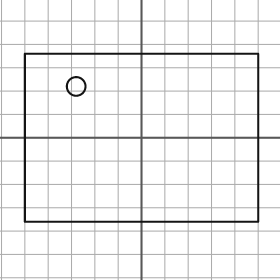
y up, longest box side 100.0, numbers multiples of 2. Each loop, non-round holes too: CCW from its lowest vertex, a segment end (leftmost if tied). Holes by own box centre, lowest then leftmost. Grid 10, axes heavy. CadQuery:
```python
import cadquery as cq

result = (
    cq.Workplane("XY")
    .moveTo(-50.0, -36.0)
    .lineTo(50.0, -36.0)
    .lineTo(50.0, 36.0)
    .lineTo(-50.0, 36.0)
    .close()
    .moveTo(-28.0, 22.0)
    .circle(4.0)
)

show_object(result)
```